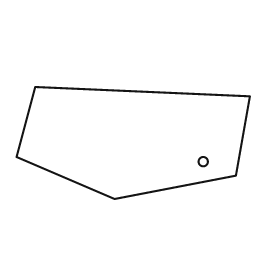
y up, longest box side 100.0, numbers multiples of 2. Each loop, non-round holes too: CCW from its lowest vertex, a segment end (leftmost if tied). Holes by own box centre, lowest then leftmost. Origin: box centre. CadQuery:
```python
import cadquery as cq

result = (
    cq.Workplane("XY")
    .moveTo(-8.0, -24.0)
    .lineTo(44.0, -14.0)
    .lineTo(50.0, 20.0)
    .lineTo(-42.0, 24.0)
    .lineTo(-50.0, -6.0)
    .close()
    .moveTo(30.0, -8.0)
    .circle(2.0)
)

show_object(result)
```